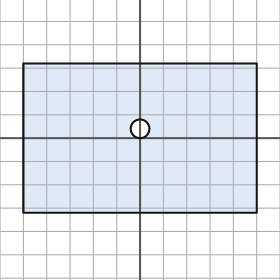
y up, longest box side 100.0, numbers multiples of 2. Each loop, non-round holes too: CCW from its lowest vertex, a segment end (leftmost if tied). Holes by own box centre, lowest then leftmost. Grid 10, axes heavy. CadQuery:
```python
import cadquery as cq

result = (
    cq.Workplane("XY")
    .moveTo(-50.0, -32.0)
    .lineTo(50.0, -32.0)
    .lineTo(50.0, 32.0)
    .lineTo(-50.0, 32.0)
    .close()
    .moveTo(0.0, 4.0)
    .circle(4.0)
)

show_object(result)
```